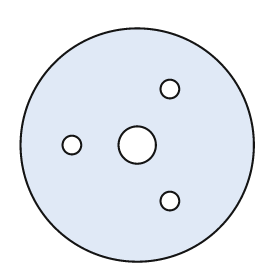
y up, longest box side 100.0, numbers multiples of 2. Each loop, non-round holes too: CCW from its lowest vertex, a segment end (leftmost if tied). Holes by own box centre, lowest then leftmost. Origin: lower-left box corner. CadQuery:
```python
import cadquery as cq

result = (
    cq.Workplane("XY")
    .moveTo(50.0, 50.0)
    .circle(50.0)
    .moveTo(64.0, 26.0)
    .circle(4.0)
    .moveTo(22.0, 50.0)
    .circle(4.0)
    .moveTo(50.0, 50.0)
    .circle(8.0)
    .moveTo(64.0, 74.0)
    .circle(4.0)
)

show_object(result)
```